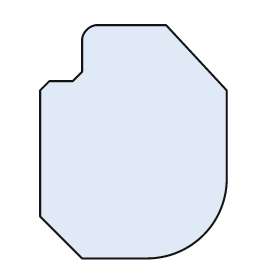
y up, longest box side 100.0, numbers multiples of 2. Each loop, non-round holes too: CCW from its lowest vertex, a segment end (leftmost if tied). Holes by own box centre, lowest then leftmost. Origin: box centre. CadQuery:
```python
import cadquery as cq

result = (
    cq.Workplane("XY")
    .moveTo(-22.0, -50.0)
    .lineTo(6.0, -50.0)
    .threePointArc((30.0, -40.0), (40.0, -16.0))
    .lineTo(40.0, 22.0)
    .lineTo(14.0, 50.0)
    .lineTo(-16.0, 50.0)
    .threePointArc((-20.0, 48.0), (-22.0, 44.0))
    .lineTo(-22.0, 30.0)
    .lineTo(-26.0, 26.0)
    .lineTo(-36.0, 26.0)
    .lineTo(-40.0, 22.0)
    .lineTo(-40.0, -32.0)
    .close()
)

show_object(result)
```